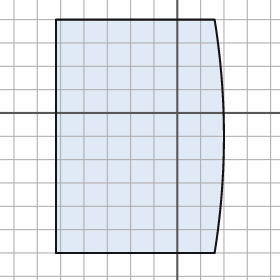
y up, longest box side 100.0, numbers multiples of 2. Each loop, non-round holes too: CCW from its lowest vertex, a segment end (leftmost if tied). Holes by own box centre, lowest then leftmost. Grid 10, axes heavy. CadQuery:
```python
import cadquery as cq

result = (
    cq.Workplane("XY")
    .moveTo(-52.0, -60.0)
    .lineTo(16.0, -60.0)
    .threePointArc((20.0, -10.0), (16.0, 40.0))
    .lineTo(-52.0, 40.0)
    .close()
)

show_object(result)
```